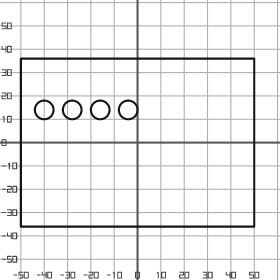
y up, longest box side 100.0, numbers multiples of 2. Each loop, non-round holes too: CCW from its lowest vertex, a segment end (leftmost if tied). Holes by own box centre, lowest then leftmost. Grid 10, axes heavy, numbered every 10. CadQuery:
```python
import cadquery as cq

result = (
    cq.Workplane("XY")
    .moveTo(-50.0, -36.0)
    .lineTo(50.0, -36.0)
    .lineTo(50.0, 36.0)
    .lineTo(-50.0, 36.0)
    .close()
    .moveTo(-40.0, 14.0)
    .circle(4.0)
    .moveTo(-28.0, 14.0)
    .circle(4.0)
    .moveTo(-16.0, 14.0)
    .circle(4.0)
    .moveTo(-4.0, 14.0)
    .circle(4.0)
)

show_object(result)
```